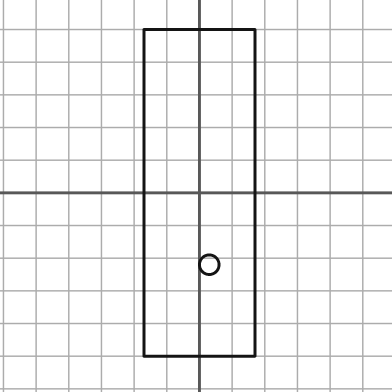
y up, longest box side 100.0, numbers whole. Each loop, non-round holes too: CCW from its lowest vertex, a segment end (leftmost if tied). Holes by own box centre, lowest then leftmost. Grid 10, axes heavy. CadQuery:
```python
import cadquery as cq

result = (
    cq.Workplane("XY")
    .moveTo(-17.0, -50.0)
    .lineTo(17.0, -50.0)
    .lineTo(17.0, 50.0)
    .lineTo(-17.0, 50.0)
    .close()
    .moveTo(3.0, -22.0)
    .circle(3.0)
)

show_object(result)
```